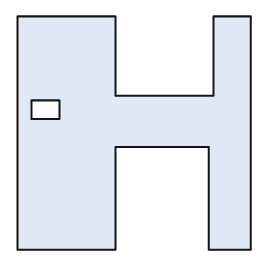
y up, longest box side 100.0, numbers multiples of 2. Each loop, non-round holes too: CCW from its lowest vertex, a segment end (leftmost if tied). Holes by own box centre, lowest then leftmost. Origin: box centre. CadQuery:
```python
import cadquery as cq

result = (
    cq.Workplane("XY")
    .moveTo(-50.0, -50.0)
    .lineTo(-8.0, -50.0)
    .lineTo(-8.0, -6.0)
    .lineTo(32.0, -6.0)
    .lineTo(32.0, -50.0)
    .lineTo(50.0, -50.0)
    .lineTo(50.0, 50.0)
    .lineTo(34.0, 50.0)
    .lineTo(34.0, 16.0)
    .lineTo(-8.0, 16.0)
    .lineTo(-8.0, 50.0)
    .lineTo(-50.0, 50.0)
    .close()
    .moveTo(-44.0, 6.0)
    .lineTo(-32.0, 6.0)
    .lineTo(-32.0, 14.0)
    .lineTo(-44.0, 14.0)
    .close()
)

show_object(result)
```